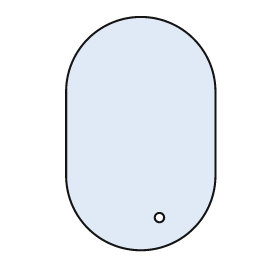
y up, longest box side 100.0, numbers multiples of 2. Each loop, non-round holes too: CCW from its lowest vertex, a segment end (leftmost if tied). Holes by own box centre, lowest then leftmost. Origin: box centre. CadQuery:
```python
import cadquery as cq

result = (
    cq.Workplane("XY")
    .moveTo(-32.0, -18.0)
    .threePointArc((0.0, -50.0), (32.0, -18.0))
    .lineTo(32.0, 18.0)
    .threePointArc((0.0, 50.0), (-32.0, 18.0))
    .close()
    .moveTo(8.0, -36.0)
    .circle(2.0)
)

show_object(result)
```